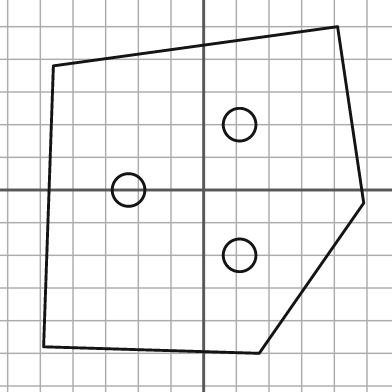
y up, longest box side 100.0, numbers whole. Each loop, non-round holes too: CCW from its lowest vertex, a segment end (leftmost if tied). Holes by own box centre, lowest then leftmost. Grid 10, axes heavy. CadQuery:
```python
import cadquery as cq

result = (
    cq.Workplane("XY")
    .moveTo(17.0, -50.0)
    .lineTo(49.0, -4.0)
    .lineTo(41.0, 50.0)
    .lineTo(-46.0, 38.0)
    .lineTo(-49.0, -48.0)
    .close()
    .moveTo(11.0, -20.0)
    .circle(5.0)
    .moveTo(-23.0, 0.0)
    .circle(5.0)
    .moveTo(11.0, 20.0)
    .circle(5.0)
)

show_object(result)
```